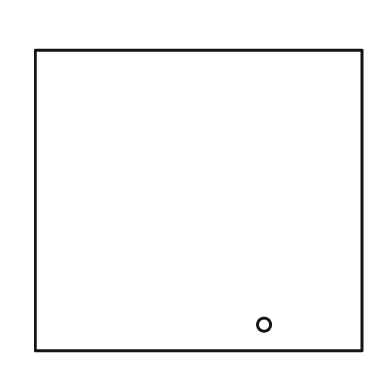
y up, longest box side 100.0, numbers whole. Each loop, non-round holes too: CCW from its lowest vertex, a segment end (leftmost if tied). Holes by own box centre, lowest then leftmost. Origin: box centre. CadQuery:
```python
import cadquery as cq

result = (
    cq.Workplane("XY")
    .moveTo(-50.0, -46.0)
    .lineTo(50.0, -46.0)
    .lineTo(50.0, 46.0)
    .lineTo(-50.0, 46.0)
    .close()
    .moveTo(20.0, -38.0)
    .circle(2.0)
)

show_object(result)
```